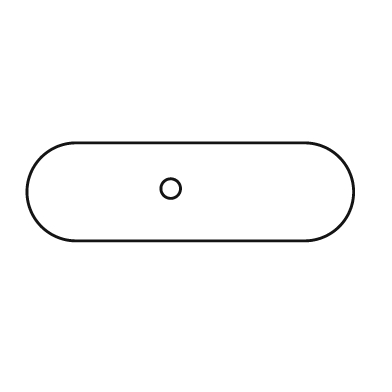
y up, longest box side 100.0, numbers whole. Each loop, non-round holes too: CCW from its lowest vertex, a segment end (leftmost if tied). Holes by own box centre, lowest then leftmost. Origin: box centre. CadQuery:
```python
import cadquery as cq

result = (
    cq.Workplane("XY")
    .moveTo(-35.0, -15.0)
    .lineTo(35.0, -15.0)
    .threePointArc((50.0, 0.0), (35.0, 15.0))
    .lineTo(-35.0, 15.0)
    .threePointArc((-50.0, 0.0), (-35.0, -15.0))
    .close()
    .moveTo(-6.0, 1.0)
    .circle(3.0)
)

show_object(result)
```